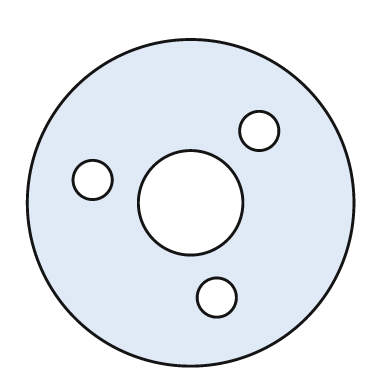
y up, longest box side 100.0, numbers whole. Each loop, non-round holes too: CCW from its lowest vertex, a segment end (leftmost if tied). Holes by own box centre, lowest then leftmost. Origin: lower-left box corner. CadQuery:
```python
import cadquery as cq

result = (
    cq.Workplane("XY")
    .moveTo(50.0, 50.0)
    .circle(50.0)
    .moveTo(58.0, 21.0)
    .circle(6.0)
    .moveTo(50.0, 50.0)
    .circle(16.0)
    .moveTo(20.0, 57.0)
    .circle(6.0)
    .moveTo(71.0, 72.0)
    .circle(6.0)
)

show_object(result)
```